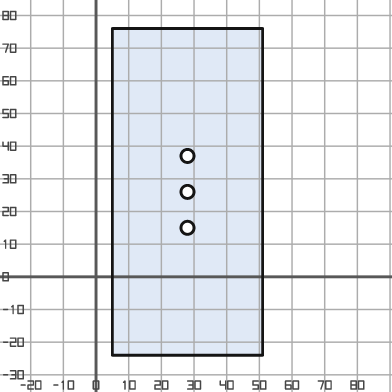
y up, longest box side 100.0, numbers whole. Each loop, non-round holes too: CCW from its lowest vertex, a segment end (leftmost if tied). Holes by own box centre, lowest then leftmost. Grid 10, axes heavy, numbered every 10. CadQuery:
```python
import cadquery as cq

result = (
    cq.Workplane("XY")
    .moveTo(5.0, -24.0)
    .lineTo(51.0, -24.0)
    .lineTo(51.0, 76.0)
    .lineTo(5.0, 76.0)
    .close()
    .moveTo(28.0, 15.0)
    .circle(2.0)
    .moveTo(28.0, 26.0)
    .circle(2.0)
    .moveTo(28.0, 37.0)
    .circle(2.0)
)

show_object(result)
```